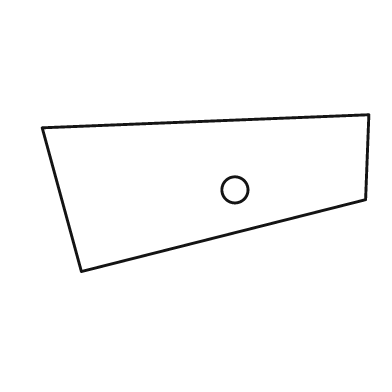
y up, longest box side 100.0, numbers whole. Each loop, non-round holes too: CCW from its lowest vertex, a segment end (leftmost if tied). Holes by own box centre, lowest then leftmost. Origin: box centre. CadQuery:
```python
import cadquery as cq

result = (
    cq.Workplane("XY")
    .moveTo(-38.0, -24.0)
    .lineTo(49.0, -2.0)
    .lineTo(50.0, 24.0)
    .lineTo(-50.0, 20.0)
    .close()
    .moveTo(9.0, 1.0)
    .circle(4.0)
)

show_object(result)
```